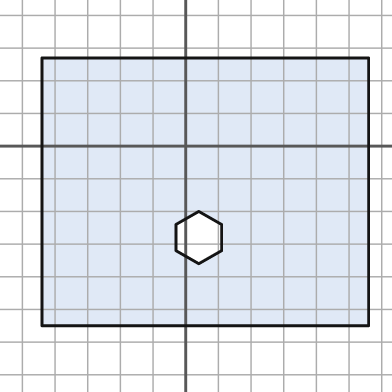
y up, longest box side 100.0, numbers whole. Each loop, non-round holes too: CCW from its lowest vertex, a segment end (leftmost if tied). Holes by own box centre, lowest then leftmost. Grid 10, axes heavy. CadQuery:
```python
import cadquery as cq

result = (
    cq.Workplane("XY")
    .moveTo(-44.0, -55.0)
    .lineTo(56.0, -55.0)
    .lineTo(56.0, 27.0)
    .lineTo(-44.0, 27.0)
    .close()
    .moveTo(4.0, -36.0)
    .lineTo(11.0, -32.0)
    .lineTo(11.0, -24.0)
    .lineTo(4.0, -20.0)
    .lineTo(-3.0, -24.0)
    .lineTo(-3.0, -32.0)
    .close()
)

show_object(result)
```